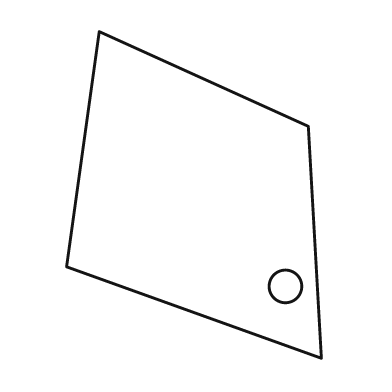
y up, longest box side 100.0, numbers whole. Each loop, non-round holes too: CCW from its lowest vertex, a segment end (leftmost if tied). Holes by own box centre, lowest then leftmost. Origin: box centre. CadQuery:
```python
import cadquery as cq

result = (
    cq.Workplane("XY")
    .moveTo(39.0, -50.0)
    .lineTo(35.0, 21.0)
    .lineTo(-29.0, 50.0)
    .lineTo(-39.0, -22.0)
    .close()
    .moveTo(28.0, -28.0)
    .circle(5.0)
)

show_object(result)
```